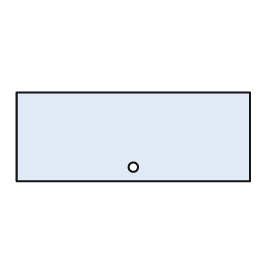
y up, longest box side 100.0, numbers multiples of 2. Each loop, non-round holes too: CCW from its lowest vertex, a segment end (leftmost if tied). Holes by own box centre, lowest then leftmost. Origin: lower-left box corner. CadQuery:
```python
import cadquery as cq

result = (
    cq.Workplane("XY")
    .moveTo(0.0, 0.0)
    .lineTo(100.0, 0.0)
    .lineTo(100.0, 38.0)
    .lineTo(0.0, 38.0)
    .close()
    .moveTo(50.0, 6.0)
    .circle(2.0)
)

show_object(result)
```